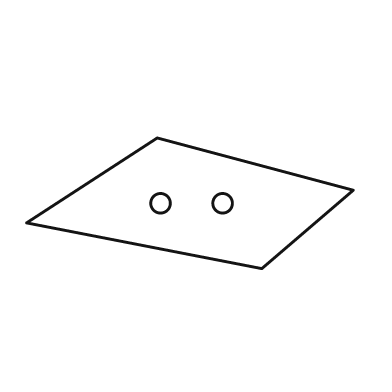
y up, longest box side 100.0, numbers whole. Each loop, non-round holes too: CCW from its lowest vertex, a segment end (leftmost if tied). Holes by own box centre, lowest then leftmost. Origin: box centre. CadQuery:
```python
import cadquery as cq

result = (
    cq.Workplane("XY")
    .moveTo(22.0, -20.0)
    .lineTo(50.0, 4.0)
    .lineTo(-10.0, 20.0)
    .lineTo(-50.0, -6.0)
    .close()
    .moveTo(-9.0, 0.0)
    .circle(3.0)
    .moveTo(10.0, 0.0)
    .circle(3.0)
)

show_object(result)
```